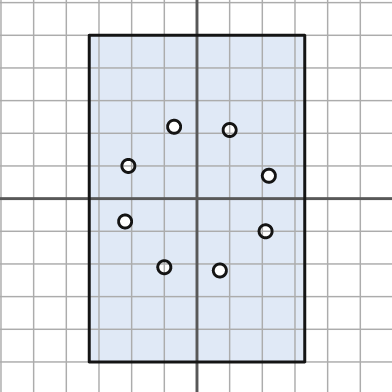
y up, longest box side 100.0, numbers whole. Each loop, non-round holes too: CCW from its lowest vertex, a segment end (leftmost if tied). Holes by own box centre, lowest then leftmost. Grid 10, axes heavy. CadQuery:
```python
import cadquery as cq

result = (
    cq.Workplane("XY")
    .moveTo(-33.0, -50.0)
    .lineTo(33.0, -50.0)
    .lineTo(33.0, 50.0)
    .lineTo(-33.0, 50.0)
    .close()
    .moveTo(7.0, -22.0)
    .circle(2.0)
    .moveTo(-10.0, -21.0)
    .circle(2.0)
    .moveTo(21.0, -10.0)
    .circle(2.0)
    .moveTo(-22.0, -7.0)
    .circle(2.0)
    .moveTo(22.0, 7.0)
    .circle(2.0)
    .moveTo(-21.0, 10.0)
    .circle(2.0)
    .moveTo(10.0, 21.0)
    .circle(2.0)
    .moveTo(-7.0, 22.0)
    .circle(2.0)
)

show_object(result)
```